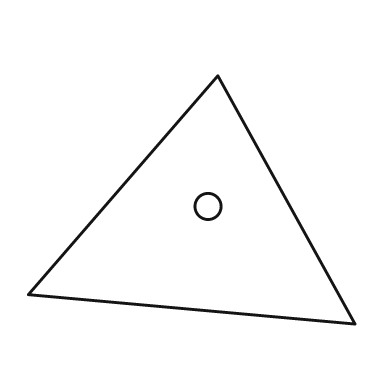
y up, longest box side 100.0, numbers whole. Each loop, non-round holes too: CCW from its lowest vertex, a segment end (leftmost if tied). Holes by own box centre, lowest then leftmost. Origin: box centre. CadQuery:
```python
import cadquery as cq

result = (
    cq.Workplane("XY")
    .moveTo(50.0, -38.0)
    .lineTo(8.0, 38.0)
    .lineTo(-50.0, -29.0)
    .close()
    .moveTo(5.0, -2.0)
    .circle(4.0)
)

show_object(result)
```